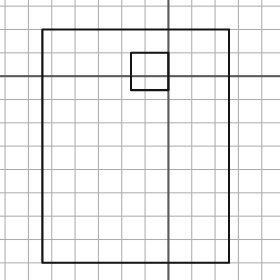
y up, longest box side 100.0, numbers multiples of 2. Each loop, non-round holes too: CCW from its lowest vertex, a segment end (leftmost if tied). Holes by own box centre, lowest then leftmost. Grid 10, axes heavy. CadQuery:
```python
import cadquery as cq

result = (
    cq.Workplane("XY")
    .moveTo(-54.0, -80.0)
    .lineTo(26.0, -80.0)
    .lineTo(26.0, 20.0)
    .lineTo(-54.0, 20.0)
    .close()
    .moveTo(-16.0, -6.0)
    .lineTo(0.0, -6.0)
    .lineTo(0.0, 10.0)
    .lineTo(-16.0, 10.0)
    .close()
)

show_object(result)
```